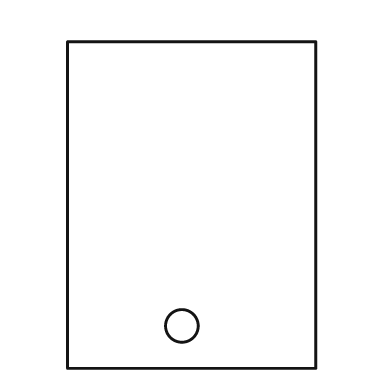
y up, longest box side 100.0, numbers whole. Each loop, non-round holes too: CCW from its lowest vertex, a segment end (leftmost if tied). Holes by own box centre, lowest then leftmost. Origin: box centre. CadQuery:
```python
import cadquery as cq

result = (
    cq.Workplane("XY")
    .moveTo(-38.0, -50.0)
    .lineTo(38.0, -50.0)
    .lineTo(38.0, 50.0)
    .lineTo(-38.0, 50.0)
    .close()
    .moveTo(-3.0, -37.0)
    .circle(5.0)
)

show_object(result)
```